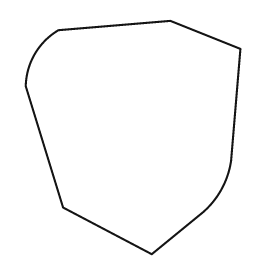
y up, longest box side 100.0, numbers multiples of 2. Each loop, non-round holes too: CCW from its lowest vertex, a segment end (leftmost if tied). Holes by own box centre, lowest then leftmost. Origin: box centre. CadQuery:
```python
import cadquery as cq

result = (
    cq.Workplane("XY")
    .moveTo(8.0, -50.0)
    .lineTo(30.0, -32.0)
    .threePointArc((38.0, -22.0), (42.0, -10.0))
    .lineTo(46.0, 38.0)
    .lineTo(16.0, 50.0)
    .lineTo(-32.0, 46.0)
    .threePointArc((-42.0, 36.0), (-46.0, 22.0))
    .lineTo(-30.0, -30.0)
    .close()
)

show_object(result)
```